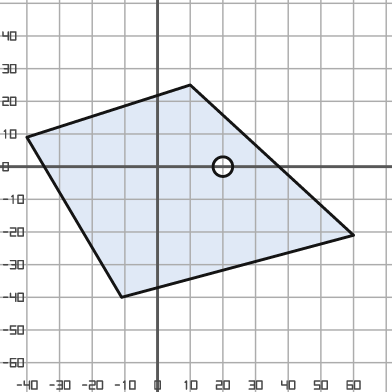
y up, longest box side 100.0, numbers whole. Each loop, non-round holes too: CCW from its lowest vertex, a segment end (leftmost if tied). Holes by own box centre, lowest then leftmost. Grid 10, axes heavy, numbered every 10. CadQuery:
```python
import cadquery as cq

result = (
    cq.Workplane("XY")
    .moveTo(-11.0, -40.0)
    .lineTo(60.0, -21.0)
    .lineTo(10.0, 25.0)
    .lineTo(-40.0, 9.0)
    .close()
    .moveTo(20.0, 0.0)
    .circle(3.0)
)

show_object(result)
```